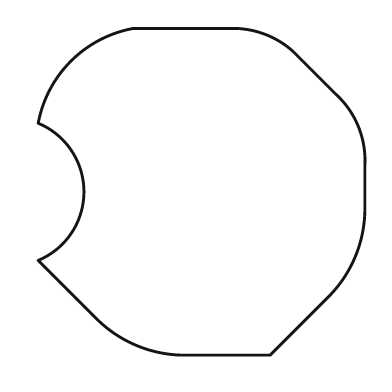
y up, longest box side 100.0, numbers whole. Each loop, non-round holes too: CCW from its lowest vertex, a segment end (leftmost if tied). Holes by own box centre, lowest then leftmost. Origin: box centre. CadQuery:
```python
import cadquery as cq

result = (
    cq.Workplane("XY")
    .moveTo(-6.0, -50.0)
    .lineTo(21.0, -50.0)
    .lineTo(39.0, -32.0)
    .threePointArc((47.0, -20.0), (50.0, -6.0))
    .lineTo(50.0, 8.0)
    .threePointArc((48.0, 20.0), (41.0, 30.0))
    .lineTo(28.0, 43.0)
    .threePointArc((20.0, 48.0), (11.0, 50.0))
    .lineTo(-21.0, 50.0)
    .threePointArc((-40.0, 40.0), (-50.0, 21.0))
    .threePointArc((-36.0, 0.0), (-50.0, -21.0))
    .lineTo(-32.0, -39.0)
    .threePointArc((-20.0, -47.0), (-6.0, -50.0))
    .close()
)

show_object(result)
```